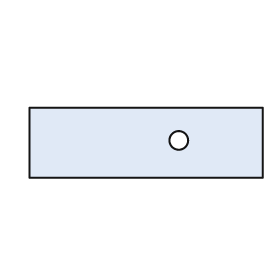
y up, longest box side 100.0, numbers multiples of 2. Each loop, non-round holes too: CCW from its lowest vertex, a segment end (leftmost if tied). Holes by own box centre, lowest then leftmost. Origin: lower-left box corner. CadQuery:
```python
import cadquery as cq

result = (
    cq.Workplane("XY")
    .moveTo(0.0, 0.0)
    .lineTo(100.0, 0.0)
    .lineTo(100.0, 30.0)
    .lineTo(0.0, 30.0)
    .close()
    .moveTo(64.0, 16.0)
    .circle(4.0)
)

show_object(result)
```